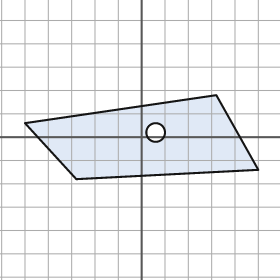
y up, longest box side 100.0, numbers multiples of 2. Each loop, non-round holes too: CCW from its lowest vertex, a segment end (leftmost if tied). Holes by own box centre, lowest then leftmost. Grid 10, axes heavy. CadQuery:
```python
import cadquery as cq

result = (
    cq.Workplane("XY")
    .moveTo(-28.0, -18.0)
    .lineTo(50.0, -14.0)
    .lineTo(32.0, 18.0)
    .lineTo(-50.0, 6.0)
    .close()
    .moveTo(6.0, 2.0)
    .circle(4.0)
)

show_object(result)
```